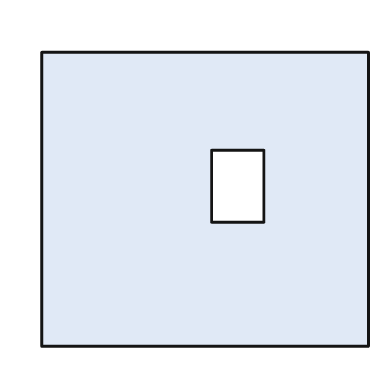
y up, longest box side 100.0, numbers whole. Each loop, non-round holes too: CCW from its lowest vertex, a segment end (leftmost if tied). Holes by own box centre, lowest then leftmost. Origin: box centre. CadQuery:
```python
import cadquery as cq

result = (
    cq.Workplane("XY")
    .moveTo(-50.0, -45.0)
    .lineTo(50.0, -45.0)
    .lineTo(50.0, 45.0)
    .lineTo(-50.0, 45.0)
    .close()
    .moveTo(2.0, -7.0)
    .lineTo(18.0, -7.0)
    .lineTo(18.0, 15.0)
    .lineTo(2.0, 15.0)
    .close()
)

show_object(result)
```